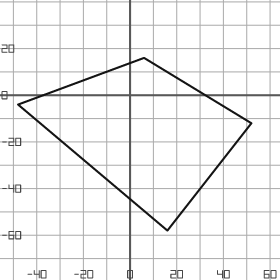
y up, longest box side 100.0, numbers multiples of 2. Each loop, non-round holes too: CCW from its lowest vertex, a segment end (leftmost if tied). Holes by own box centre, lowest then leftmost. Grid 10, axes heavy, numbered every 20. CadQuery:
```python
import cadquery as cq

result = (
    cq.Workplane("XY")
    .moveTo(16.0, -58.0)
    .lineTo(52.0, -12.0)
    .lineTo(6.0, 16.0)
    .lineTo(-48.0, -4.0)
    .close()
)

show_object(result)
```